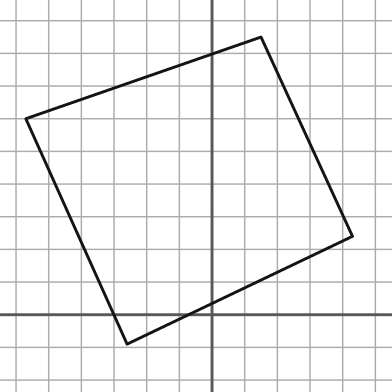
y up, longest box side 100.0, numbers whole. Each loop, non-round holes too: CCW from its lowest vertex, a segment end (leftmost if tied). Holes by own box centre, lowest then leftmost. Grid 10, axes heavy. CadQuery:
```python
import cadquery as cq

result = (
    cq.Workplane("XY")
    .moveTo(-26.0, -9.0)
    .lineTo(43.0, 24.0)
    .lineTo(15.0, 85.0)
    .lineTo(-57.0, 60.0)
    .close()
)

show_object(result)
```